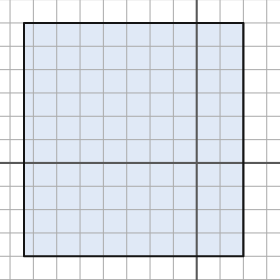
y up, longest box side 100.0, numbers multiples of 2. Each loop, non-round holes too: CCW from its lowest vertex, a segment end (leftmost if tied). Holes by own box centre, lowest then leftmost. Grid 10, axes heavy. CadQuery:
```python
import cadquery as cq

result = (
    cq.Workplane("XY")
    .moveTo(-74.0, -40.0)
    .lineTo(20.0, -40.0)
    .lineTo(20.0, 60.0)
    .lineTo(-74.0, 60.0)
    .close()
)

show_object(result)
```